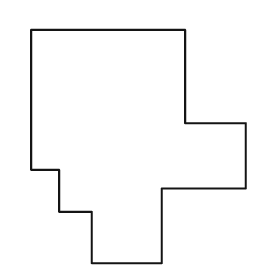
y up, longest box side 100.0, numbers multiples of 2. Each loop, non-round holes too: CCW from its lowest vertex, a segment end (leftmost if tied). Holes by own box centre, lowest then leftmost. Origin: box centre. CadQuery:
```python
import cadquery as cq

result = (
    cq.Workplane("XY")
    .moveTo(-20.0, -50.0)
    .lineTo(10.0, -50.0)
    .lineTo(10.0, -18.0)
    .lineTo(46.0, -18.0)
    .lineTo(46.0, 10.0)
    .lineTo(20.0, 10.0)
    .lineTo(20.0, 50.0)
    .lineTo(-46.0, 50.0)
    .lineTo(-46.0, -10.0)
    .lineTo(-34.0, -10.0)
    .lineTo(-34.0, -28.0)
    .lineTo(-20.0, -28.0)
    .close()
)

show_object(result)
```